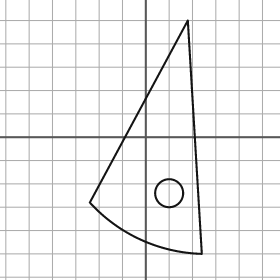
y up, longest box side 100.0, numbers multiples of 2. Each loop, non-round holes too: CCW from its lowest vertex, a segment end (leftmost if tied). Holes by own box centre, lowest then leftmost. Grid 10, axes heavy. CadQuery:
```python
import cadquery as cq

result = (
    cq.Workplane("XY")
    .moveTo(24.0, -50.0)
    .lineTo(18.0, 50.0)
    .lineTo(-24.0, -28.0)
    .threePointArc((-2.0, -44.0), (24.0, -50.0))
    .close()
    .moveTo(10.0, -24.0)
    .circle(6.0)
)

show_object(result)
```